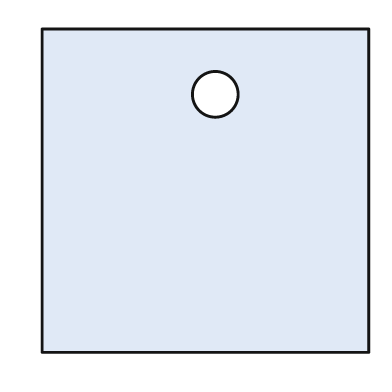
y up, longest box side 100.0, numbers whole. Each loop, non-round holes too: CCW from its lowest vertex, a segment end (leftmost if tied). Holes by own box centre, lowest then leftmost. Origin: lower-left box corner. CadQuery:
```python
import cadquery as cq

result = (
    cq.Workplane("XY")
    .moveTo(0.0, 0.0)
    .lineTo(100.0, 0.0)
    .lineTo(100.0, 99.0)
    .lineTo(0.0, 99.0)
    .close()
    .moveTo(53.0, 79.0)
    .circle(7.0)
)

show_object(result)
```